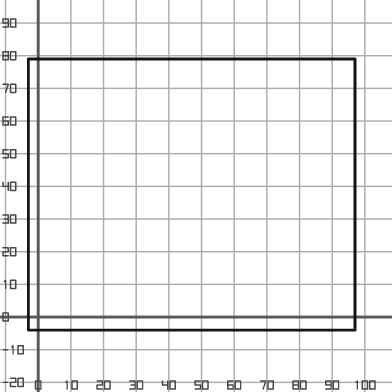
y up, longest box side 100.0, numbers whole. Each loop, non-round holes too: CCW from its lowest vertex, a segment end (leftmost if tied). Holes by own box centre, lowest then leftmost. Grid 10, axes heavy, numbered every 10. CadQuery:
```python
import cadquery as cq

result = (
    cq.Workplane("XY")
    .moveTo(-3.0, -4.0)
    .lineTo(97.0, -4.0)
    .lineTo(97.0, 79.0)
    .lineTo(-3.0, 79.0)
    .close()
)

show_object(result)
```